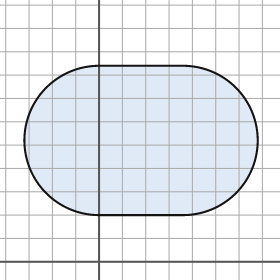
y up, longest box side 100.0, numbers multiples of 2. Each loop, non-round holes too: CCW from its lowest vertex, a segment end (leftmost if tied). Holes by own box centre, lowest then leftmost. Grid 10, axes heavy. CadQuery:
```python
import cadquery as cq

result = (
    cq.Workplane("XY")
    .moveTo(0.0, 20.0)
    .lineTo(36.0, 20.0)
    .threePointArc((68.0, 52.0), (36.0, 84.0))
    .lineTo(0.0, 84.0)
    .threePointArc((-32.0, 52.0), (0.0, 20.0))
    .close()
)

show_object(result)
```